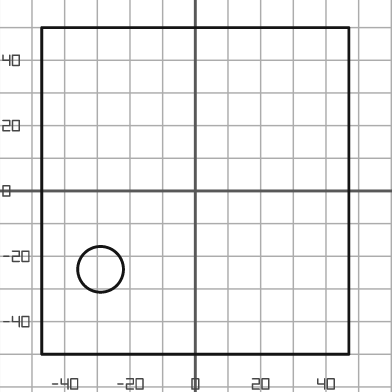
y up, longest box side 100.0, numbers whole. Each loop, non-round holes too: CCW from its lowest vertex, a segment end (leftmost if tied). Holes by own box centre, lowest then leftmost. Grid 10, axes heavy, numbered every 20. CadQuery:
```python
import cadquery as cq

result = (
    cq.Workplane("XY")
    .moveTo(-47.0, -50.0)
    .lineTo(47.0, -50.0)
    .lineTo(47.0, 50.0)
    .lineTo(-47.0, 50.0)
    .close()
    .moveTo(-29.0, -24.0)
    .circle(7.0)
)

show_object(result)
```